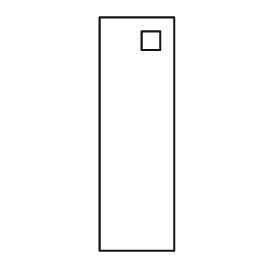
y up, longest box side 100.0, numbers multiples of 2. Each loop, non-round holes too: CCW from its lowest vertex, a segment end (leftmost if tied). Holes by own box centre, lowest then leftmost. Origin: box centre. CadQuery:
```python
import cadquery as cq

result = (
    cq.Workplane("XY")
    .moveTo(-16.0, -50.0)
    .lineTo(16.0, -50.0)
    .lineTo(16.0, 50.0)
    .lineTo(-16.0, 50.0)
    .close()
    .moveTo(2.0, 36.0)
    .lineTo(10.0, 36.0)
    .lineTo(10.0, 44.0)
    .lineTo(2.0, 44.0)
    .close()
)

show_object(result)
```